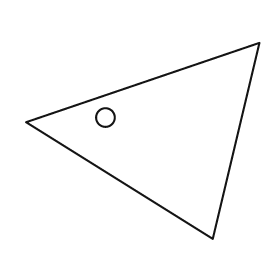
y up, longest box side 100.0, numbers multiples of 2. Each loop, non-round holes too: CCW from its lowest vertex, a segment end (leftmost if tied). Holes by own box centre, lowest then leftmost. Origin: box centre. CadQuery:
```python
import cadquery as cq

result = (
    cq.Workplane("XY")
    .moveTo(30.0, -42.0)
    .lineTo(50.0, 42.0)
    .lineTo(-50.0, 8.0)
    .close()
    .moveTo(-16.0, 10.0)
    .circle(4.0)
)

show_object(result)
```